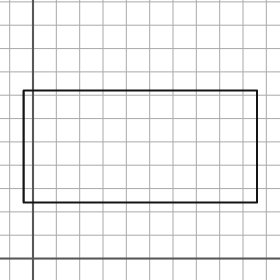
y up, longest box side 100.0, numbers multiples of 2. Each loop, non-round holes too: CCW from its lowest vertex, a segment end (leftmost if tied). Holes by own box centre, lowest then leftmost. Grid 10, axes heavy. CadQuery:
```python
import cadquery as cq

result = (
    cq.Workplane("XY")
    .moveTo(-4.0, 24.0)
    .lineTo(96.0, 24.0)
    .lineTo(96.0, 72.0)
    .lineTo(-4.0, 72.0)
    .close()
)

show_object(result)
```